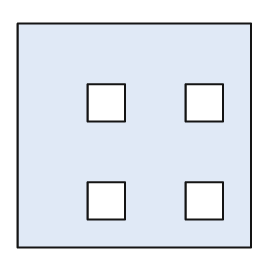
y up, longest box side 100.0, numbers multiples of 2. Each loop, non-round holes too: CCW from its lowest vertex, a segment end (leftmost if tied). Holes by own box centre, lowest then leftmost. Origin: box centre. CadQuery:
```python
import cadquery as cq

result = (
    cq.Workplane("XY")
    .moveTo(-50.0, -48.0)
    .lineTo(50.0, -48.0)
    .lineTo(50.0, 48.0)
    .lineTo(-50.0, 48.0)
    .close()
    .moveTo(-20.0, -36.0)
    .lineTo(-4.0, -36.0)
    .lineTo(-4.0, -20.0)
    .lineTo(-20.0, -20.0)
    .close()
    .moveTo(22.0, -36.0)
    .lineTo(38.0, -36.0)
    .lineTo(38.0, -20.0)
    .lineTo(22.0, -20.0)
    .close()
    .moveTo(-20.0, 6.0)
    .lineTo(-4.0, 6.0)
    .lineTo(-4.0, 22.0)
    .lineTo(-20.0, 22.0)
    .close()
    .moveTo(22.0, 6.0)
    .lineTo(38.0, 6.0)
    .lineTo(38.0, 22.0)
    .lineTo(22.0, 22.0)
    .close()
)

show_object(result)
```